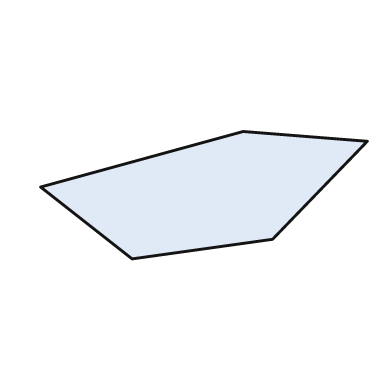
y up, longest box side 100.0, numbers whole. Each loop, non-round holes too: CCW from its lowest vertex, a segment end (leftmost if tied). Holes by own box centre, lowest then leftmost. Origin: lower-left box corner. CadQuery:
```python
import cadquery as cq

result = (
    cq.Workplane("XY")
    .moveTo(28.0, 0.0)
    .lineTo(71.0, 6.0)
    .lineTo(100.0, 36.0)
    .lineTo(62.0, 39.0)
    .lineTo(0.0, 22.0)
    .close()
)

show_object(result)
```